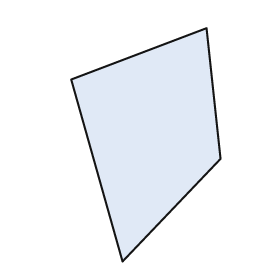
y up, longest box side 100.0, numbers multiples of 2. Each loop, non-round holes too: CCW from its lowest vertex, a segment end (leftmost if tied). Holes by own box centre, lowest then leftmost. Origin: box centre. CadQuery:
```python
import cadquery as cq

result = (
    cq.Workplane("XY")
    .moveTo(-10.0, -50.0)
    .lineTo(32.0, -6.0)
    .lineTo(26.0, 50.0)
    .lineTo(-32.0, 28.0)
    .close()
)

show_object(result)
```